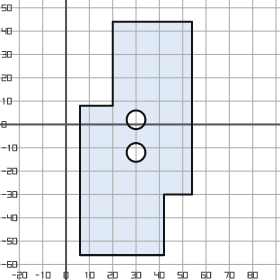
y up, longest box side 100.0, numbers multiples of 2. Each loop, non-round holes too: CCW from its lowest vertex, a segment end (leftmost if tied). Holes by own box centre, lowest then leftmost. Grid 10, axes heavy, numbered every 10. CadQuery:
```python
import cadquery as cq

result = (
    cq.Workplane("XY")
    .moveTo(6.0, -56.0)
    .lineTo(42.0, -56.0)
    .lineTo(42.0, -30.0)
    .lineTo(54.0, -30.0)
    .lineTo(54.0, 44.0)
    .lineTo(20.0, 44.0)
    .lineTo(20.0, 8.0)
    .lineTo(6.0, 8.0)
    .close()
    .moveTo(30.0, -12.0)
    .circle(4.0)
    .moveTo(30.0, 2.0)
    .circle(4.0)
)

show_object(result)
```